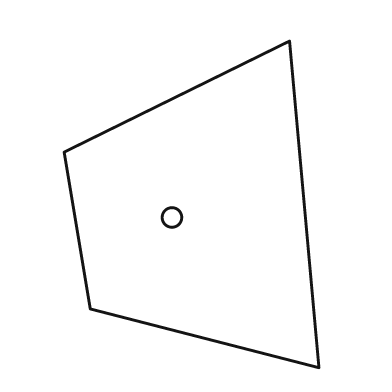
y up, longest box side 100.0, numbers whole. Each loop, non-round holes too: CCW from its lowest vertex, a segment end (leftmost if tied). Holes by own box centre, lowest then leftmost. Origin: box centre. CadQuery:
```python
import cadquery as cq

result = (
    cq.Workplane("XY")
    .moveTo(39.0, -50.0)
    .lineTo(30.0, 50.0)
    .lineTo(-39.0, 16.0)
    .lineTo(-31.0, -32.0)
    .close()
    .moveTo(-6.0, -4.0)
    .circle(3.0)
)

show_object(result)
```